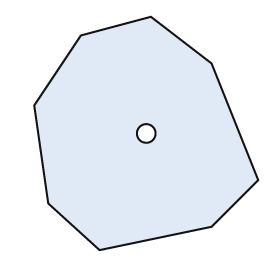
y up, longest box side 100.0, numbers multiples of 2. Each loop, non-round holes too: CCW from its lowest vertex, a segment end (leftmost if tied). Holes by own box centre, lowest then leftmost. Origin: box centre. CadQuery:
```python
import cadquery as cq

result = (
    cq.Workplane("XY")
    .moveTo(-20.0, -50.0)
    .lineTo(28.0, -40.0)
    .lineTo(48.0, -20.0)
    .lineTo(28.0, 30.0)
    .lineTo(2.0, 50.0)
    .lineTo(-28.0, 42.0)
    .lineTo(-48.0, 12.0)
    .lineTo(-42.0, -30.0)
    .close()
    .moveTo(0.0, 0.0)
    .circle(4.0)
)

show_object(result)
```